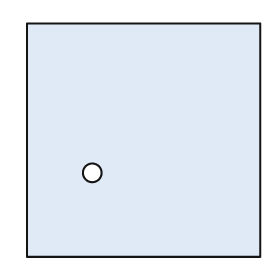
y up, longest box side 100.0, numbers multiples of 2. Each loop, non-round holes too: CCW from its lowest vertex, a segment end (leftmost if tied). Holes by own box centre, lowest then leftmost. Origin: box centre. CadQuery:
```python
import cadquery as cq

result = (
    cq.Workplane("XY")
    .moveTo(-50.0, -50.0)
    .lineTo(50.0, -50.0)
    .lineTo(50.0, 50.0)
    .lineTo(-50.0, 50.0)
    .close()
    .moveTo(-22.0, -14.0)
    .circle(4.0)
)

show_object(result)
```